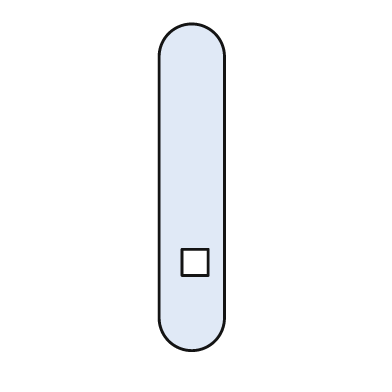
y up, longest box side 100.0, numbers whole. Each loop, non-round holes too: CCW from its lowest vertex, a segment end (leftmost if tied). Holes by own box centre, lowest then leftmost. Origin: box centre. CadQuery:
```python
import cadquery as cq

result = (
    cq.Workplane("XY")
    .moveTo(-10.0, -40.0)
    .threePointArc((0.0, -50.0), (10.0, -40.0))
    .lineTo(10.0, 40.0)
    .threePointArc((0.0, 50.0), (-10.0, 40.0))
    .close()
    .moveTo(-3.0, -27.0)
    .lineTo(5.0, -27.0)
    .lineTo(5.0, -19.0)
    .lineTo(-3.0, -19.0)
    .close()
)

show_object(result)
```